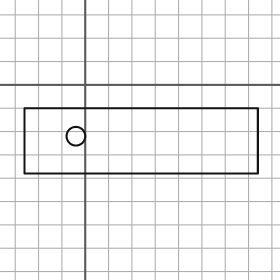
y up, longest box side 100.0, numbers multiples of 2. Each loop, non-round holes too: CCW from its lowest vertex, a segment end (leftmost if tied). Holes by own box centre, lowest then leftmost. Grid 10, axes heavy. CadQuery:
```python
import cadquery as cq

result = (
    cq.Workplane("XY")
    .moveTo(-26.0, -38.0)
    .lineTo(74.0, -38.0)
    .lineTo(74.0, -10.0)
    .lineTo(-26.0, -10.0)
    .close()
    .moveTo(-4.0, -22.0)
    .circle(4.0)
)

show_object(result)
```